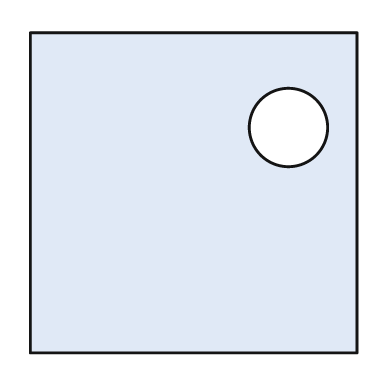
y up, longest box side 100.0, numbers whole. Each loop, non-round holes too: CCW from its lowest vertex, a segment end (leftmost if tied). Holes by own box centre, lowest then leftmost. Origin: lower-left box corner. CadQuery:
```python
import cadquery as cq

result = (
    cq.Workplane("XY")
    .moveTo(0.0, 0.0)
    .lineTo(100.0, 0.0)
    .lineTo(100.0, 98.0)
    .lineTo(0.0, 98.0)
    .close()
    .moveTo(79.0, 69.0)
    .circle(12.0)
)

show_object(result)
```